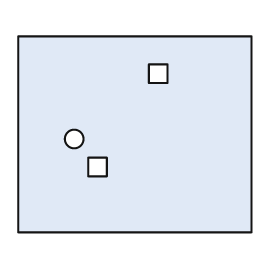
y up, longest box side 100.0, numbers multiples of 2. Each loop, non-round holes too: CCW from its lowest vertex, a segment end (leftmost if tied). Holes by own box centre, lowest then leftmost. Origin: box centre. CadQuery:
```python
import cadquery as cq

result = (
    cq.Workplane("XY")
    .moveTo(-50.0, -42.0)
    .lineTo(50.0, -42.0)
    .lineTo(50.0, 42.0)
    .lineTo(-50.0, 42.0)
    .close()
    .moveTo(-20.0, -18.0)
    .lineTo(-12.0, -18.0)
    .lineTo(-12.0, -10.0)
    .lineTo(-20.0, -10.0)
    .close()
    .moveTo(-26.0, -2.0)
    .circle(4.0)
    .moveTo(6.0, 22.0)
    .lineTo(14.0, 22.0)
    .lineTo(14.0, 30.0)
    .lineTo(6.0, 30.0)
    .close()
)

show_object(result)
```